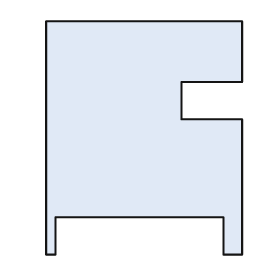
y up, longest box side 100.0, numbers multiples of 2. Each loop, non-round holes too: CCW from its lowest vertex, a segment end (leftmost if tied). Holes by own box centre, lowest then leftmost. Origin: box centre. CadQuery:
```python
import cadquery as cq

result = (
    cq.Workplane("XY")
    .moveTo(-42.0, -50.0)
    .lineTo(-38.0, -50.0)
    .lineTo(-38.0, -34.0)
    .lineTo(34.0, -34.0)
    .lineTo(34.0, -50.0)
    .lineTo(42.0, -50.0)
    .lineTo(42.0, 8.0)
    .lineTo(16.0, 8.0)
    .lineTo(16.0, 24.0)
    .lineTo(42.0, 24.0)
    .lineTo(42.0, 50.0)
    .lineTo(-42.0, 50.0)
    .close()
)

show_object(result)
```